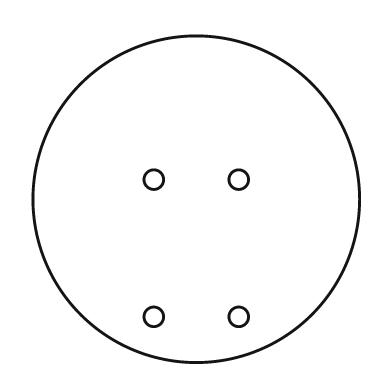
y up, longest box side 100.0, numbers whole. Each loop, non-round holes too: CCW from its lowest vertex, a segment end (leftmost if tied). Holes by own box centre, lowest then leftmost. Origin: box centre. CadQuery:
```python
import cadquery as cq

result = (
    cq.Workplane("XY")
    .moveTo(0.0, 0.0)
    .circle(50.0)
    .moveTo(-13.0, -36.0)
    .circle(3.0)
    .moveTo(13.0, -36.0)
    .circle(3.0)
    .moveTo(-13.0, 6.0)
    .circle(3.0)
    .moveTo(13.0, 6.0)
    .circle(3.0)
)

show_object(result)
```